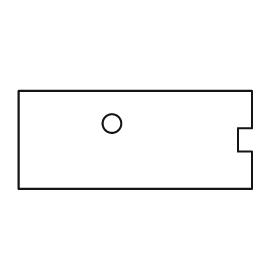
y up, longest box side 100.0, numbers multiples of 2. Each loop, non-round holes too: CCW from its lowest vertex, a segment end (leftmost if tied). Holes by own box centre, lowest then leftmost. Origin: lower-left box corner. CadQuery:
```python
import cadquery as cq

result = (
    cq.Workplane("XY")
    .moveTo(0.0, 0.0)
    .lineTo(100.0, 0.0)
    .lineTo(100.0, 16.0)
    .lineTo(94.0, 16.0)
    .lineTo(94.0, 26.0)
    .lineTo(100.0, 26.0)
    .lineTo(100.0, 42.0)
    .lineTo(0.0, 42.0)
    .close()
    .moveTo(40.0, 28.0)
    .circle(4.0)
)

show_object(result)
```